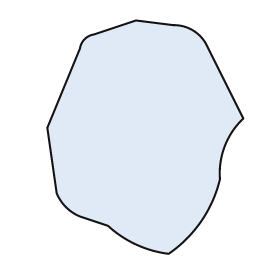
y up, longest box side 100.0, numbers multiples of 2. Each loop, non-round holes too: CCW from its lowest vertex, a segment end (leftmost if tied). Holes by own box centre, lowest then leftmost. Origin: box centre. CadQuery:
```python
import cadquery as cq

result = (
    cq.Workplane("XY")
    .moveTo(10.0, -50.0)
    .threePointArc((24.0, -36.0), (32.0, -18.0))
    .threePointArc((34.0, -4.0), (42.0, 8.0))
    .lineTo(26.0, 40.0)
    .threePointArc((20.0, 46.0), (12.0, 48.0))
    .lineTo(-4.0, 50.0)
    .lineTo(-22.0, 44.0)
    .threePointArc((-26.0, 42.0), (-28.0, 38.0))
    .lineTo(-42.0, 4.0)
    .lineTo(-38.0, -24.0)
    .threePointArc((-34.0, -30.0), (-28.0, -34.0))
    .lineTo(-16.0, -38.0)
    .threePointArc((-4.0, -46.0), (10.0, -50.0))
    .close()
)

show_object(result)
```